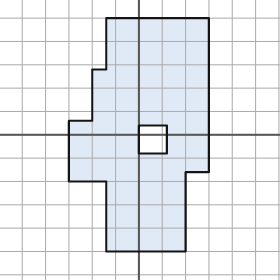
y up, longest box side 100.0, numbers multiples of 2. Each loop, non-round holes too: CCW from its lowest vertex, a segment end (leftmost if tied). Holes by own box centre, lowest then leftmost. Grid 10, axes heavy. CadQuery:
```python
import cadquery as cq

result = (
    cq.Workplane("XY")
    .moveTo(-14.0, -50.0)
    .lineTo(20.0, -50.0)
    .lineTo(20.0, -16.0)
    .lineTo(30.0, -16.0)
    .lineTo(30.0, 50.0)
    .lineTo(-14.0, 50.0)
    .lineTo(-14.0, 28.0)
    .lineTo(-20.0, 28.0)
    .lineTo(-20.0, 6.0)
    .lineTo(-30.0, 6.0)
    .lineTo(-30.0, -20.0)
    .lineTo(-14.0, -20.0)
    .close()
    .moveTo(0.0, -8.0)
    .lineTo(12.0, -8.0)
    .lineTo(12.0, 4.0)
    .lineTo(0.0, 4.0)
    .close()
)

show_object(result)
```